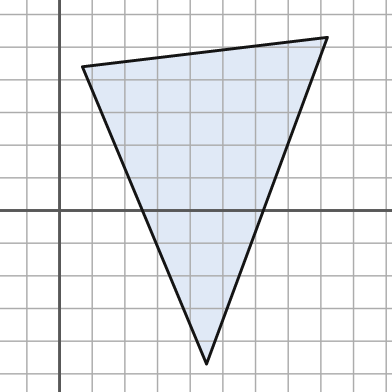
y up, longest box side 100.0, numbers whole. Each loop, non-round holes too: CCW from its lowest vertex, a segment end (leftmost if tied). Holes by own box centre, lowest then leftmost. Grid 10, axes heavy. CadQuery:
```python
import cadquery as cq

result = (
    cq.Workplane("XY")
    .moveTo(45.0, -47.0)
    .lineTo(82.0, 53.0)
    .lineTo(7.0, 44.0)
    .close()
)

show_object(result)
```